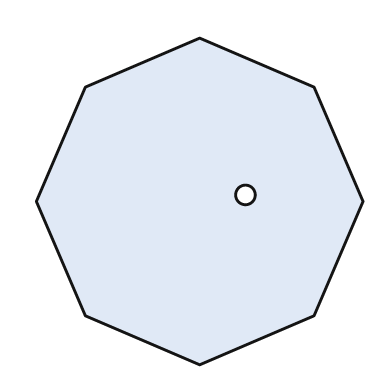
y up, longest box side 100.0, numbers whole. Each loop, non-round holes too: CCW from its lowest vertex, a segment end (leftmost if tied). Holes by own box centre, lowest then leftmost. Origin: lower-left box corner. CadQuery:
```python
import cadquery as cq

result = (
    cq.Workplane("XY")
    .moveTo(50.0, 0.0)
    .lineTo(85.0, 15.0)
    .lineTo(100.0, 50.0)
    .lineTo(85.0, 85.0)
    .lineTo(50.0, 100.0)
    .lineTo(15.0, 85.0)
    .lineTo(0.0, 50.0)
    .lineTo(15.0, 15.0)
    .close()
    .moveTo(64.0, 52.0)
    .circle(3.0)
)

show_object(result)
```